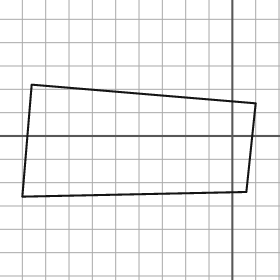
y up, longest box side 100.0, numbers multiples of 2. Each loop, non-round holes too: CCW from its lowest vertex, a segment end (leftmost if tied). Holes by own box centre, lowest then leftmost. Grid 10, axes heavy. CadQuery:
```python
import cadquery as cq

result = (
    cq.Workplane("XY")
    .moveTo(-90.0, -26.0)
    .lineTo(6.0, -24.0)
    .lineTo(10.0, 14.0)
    .lineTo(-86.0, 22.0)
    .close()
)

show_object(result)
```